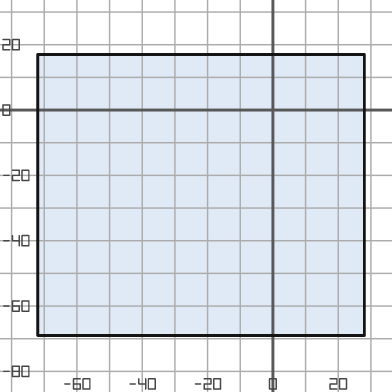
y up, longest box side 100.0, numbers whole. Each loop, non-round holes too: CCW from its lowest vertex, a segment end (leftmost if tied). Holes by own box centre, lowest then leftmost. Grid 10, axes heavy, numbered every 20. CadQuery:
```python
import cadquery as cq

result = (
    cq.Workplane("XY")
    .moveTo(-72.0, -69.0)
    .lineTo(28.0, -69.0)
    .lineTo(28.0, 17.0)
    .lineTo(-72.0, 17.0)
    .close()
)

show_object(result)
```